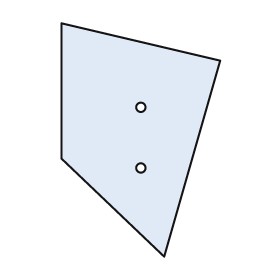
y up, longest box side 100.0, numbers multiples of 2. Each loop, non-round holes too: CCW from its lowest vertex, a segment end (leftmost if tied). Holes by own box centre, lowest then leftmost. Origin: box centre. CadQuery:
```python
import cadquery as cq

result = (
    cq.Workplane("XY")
    .moveTo(10.0, -50.0)
    .lineTo(34.0, 34.0)
    .lineTo(-34.0, 50.0)
    .lineTo(-34.0, -8.0)
    .close()
    .moveTo(0.0, -12.0)
    .circle(2.0)
    .moveTo(0.0, 14.0)
    .circle(2.0)
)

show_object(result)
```